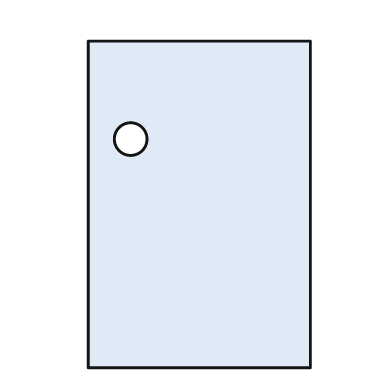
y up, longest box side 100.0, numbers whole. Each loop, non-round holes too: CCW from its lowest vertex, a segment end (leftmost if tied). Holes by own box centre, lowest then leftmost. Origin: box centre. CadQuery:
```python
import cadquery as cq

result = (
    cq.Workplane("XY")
    .moveTo(-34.0, -50.0)
    .lineTo(34.0, -50.0)
    .lineTo(34.0, 50.0)
    .lineTo(-34.0, 50.0)
    .close()
    .moveTo(-21.0, 20.0)
    .circle(5.0)
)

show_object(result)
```